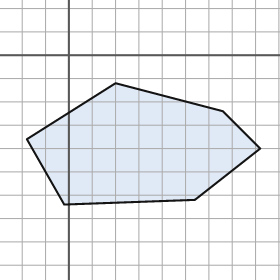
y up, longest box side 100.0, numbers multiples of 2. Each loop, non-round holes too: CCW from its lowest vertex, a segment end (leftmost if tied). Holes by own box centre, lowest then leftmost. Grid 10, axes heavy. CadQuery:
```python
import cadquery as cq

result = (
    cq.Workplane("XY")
    .moveTo(-2.0, -64.0)
    .lineTo(54.0, -62.0)
    .lineTo(82.0, -40.0)
    .lineTo(66.0, -24.0)
    .lineTo(20.0, -12.0)
    .lineTo(-18.0, -36.0)
    .close()
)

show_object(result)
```